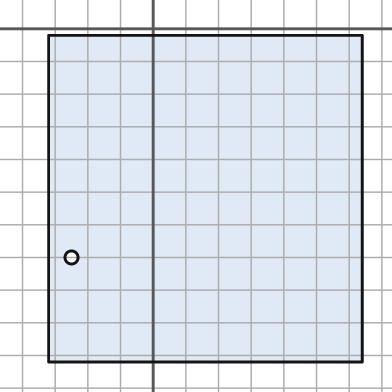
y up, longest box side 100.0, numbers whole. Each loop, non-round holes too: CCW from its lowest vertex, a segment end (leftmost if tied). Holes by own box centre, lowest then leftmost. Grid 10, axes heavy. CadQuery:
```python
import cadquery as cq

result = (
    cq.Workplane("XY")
    .moveTo(-32.0, -102.0)
    .lineTo(64.0, -102.0)
    .lineTo(64.0, -2.0)
    .lineTo(-32.0, -2.0)
    .close()
    .moveTo(-25.0, -70.0)
    .circle(2.0)
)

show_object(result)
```